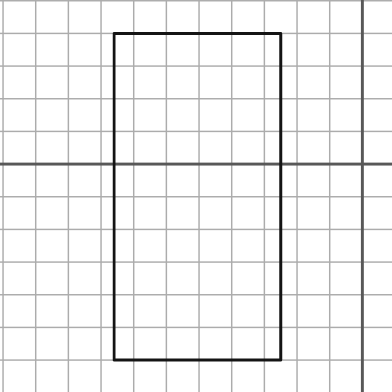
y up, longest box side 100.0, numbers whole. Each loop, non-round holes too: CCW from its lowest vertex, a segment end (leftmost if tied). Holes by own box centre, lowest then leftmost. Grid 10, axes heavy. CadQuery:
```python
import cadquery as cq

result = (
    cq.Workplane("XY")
    .moveTo(-76.0, -60.0)
    .lineTo(-25.0, -60.0)
    .lineTo(-25.0, 40.0)
    .lineTo(-76.0, 40.0)
    .close()
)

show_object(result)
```